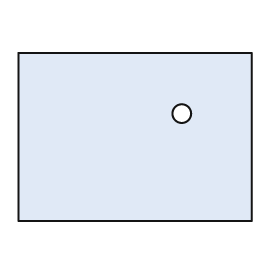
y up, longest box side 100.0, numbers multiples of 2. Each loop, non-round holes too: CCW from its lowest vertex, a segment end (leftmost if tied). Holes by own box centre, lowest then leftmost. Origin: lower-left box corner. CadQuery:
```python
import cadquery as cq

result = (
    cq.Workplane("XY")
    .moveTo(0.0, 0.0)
    .lineTo(100.0, 0.0)
    .lineTo(100.0, 72.0)
    .lineTo(0.0, 72.0)
    .close()
    .moveTo(70.0, 46.0)
    .circle(4.0)
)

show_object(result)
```